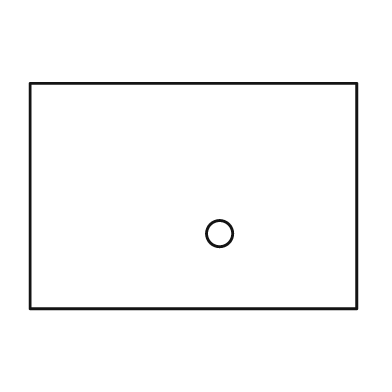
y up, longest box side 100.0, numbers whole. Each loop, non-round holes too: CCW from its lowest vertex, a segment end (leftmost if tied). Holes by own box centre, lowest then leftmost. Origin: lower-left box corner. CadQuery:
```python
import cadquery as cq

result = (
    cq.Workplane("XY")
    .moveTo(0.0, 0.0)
    .lineTo(100.0, 0.0)
    .lineTo(100.0, 69.0)
    .lineTo(0.0, 69.0)
    .close()
    .moveTo(58.0, 23.0)
    .circle(4.0)
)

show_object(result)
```